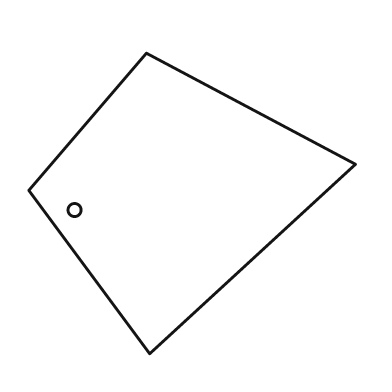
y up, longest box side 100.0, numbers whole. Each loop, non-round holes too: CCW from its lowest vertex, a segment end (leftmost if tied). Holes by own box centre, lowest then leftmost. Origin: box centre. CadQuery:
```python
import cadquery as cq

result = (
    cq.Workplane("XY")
    .moveTo(-13.0, -46.0)
    .lineTo(50.0, 12.0)
    .lineTo(-14.0, 46.0)
    .lineTo(-50.0, 4.0)
    .close()
    .moveTo(-36.0, -2.0)
    .circle(2.0)
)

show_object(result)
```